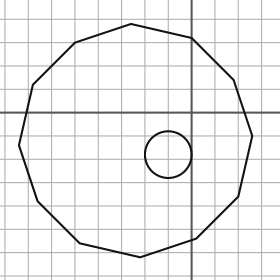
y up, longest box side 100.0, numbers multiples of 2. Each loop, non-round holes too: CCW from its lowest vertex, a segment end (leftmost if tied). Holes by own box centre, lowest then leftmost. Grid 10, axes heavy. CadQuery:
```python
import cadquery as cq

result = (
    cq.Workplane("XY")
    .moveTo(-22.0, -62.0)
    .lineTo(2.0, -54.0)
    .lineTo(20.0, -36.0)
    .lineTo(26.0, -10.0)
    .lineTo(18.0, 14.0)
    .lineTo(0.0, 32.0)
    .lineTo(-26.0, 38.0)
    .lineTo(-50.0, 30.0)
    .lineTo(-68.0, 12.0)
    .lineTo(-74.0, -14.0)
    .lineTo(-66.0, -38.0)
    .lineTo(-48.0, -56.0)
    .close()
    .moveTo(-10.0, -18.0)
    .circle(10.0)
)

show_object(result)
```